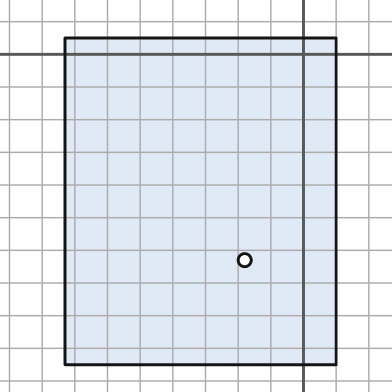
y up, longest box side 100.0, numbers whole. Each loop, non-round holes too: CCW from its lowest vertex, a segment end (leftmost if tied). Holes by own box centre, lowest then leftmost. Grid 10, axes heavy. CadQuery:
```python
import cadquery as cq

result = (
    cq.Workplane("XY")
    .moveTo(-73.0, -95.0)
    .lineTo(10.0, -95.0)
    .lineTo(10.0, 5.0)
    .lineTo(-73.0, 5.0)
    .close()
    .moveTo(-18.0, -63.0)
    .circle(2.0)
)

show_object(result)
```